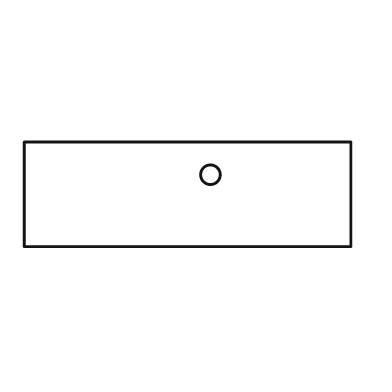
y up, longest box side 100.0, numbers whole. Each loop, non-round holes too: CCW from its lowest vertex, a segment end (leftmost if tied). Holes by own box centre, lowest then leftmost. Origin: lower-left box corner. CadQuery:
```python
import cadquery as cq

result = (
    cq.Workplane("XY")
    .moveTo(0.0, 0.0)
    .lineTo(100.0, 0.0)
    .lineTo(100.0, 32.0)
    .lineTo(0.0, 32.0)
    .close()
    .moveTo(57.0, 22.0)
    .circle(3.0)
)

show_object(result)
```